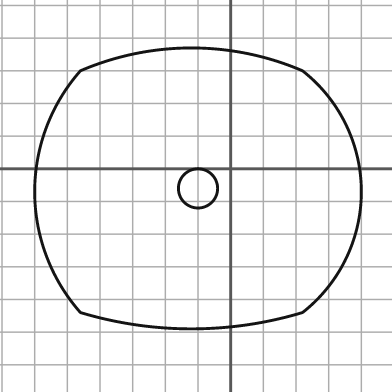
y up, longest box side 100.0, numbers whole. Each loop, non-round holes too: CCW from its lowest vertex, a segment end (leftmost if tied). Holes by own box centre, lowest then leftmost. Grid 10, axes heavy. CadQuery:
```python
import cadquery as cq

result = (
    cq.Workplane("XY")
    .moveTo(-46.0, -44.0)
    .threePointArc((-12.0, -49.0), (22.0, -44.0))
    .threePointArc((40.0, -7.0), (22.0, 30.0))
    .threePointArc((-12.0, 37.0), (-46.0, 30.0))
    .threePointArc((-60.0, -7.0), (-46.0, -44.0))
    .close()
    .moveTo(-10.0, -6.0)
    .circle(6.0)
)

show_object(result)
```